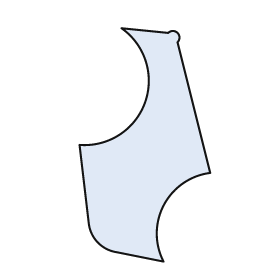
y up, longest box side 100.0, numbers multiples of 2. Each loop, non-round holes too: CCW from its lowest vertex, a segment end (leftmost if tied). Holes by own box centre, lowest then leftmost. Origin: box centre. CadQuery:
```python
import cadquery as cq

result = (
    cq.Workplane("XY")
    .moveTo(8.0, -50.0)
    .threePointArc((8.0, -26.0), (28.0, -12.0))
    .lineTo(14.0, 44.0)
    .threePointArc((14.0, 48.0), (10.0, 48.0))
    .lineTo(-10.0, 50.0)
    .threePointArc((0.0, 18.0), (-28.0, 0.0))
    .lineTo(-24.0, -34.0)
    .threePointArc((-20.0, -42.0), (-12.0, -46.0))
    .close()
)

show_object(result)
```